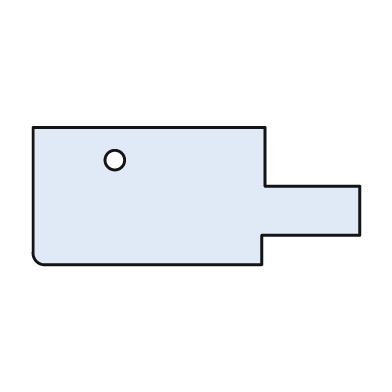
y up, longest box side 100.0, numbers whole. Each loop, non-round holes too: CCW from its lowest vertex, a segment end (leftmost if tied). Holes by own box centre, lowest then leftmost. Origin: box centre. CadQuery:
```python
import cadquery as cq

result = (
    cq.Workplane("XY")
    .moveTo(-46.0, -21.0)
    .lineTo(20.0, -21.0)
    .lineTo(20.0, -12.0)
    .lineTo(50.0, -12.0)
    .lineTo(50.0, 3.0)
    .lineTo(21.0, 3.0)
    .lineTo(21.0, 21.0)
    .lineTo(-50.0, 21.0)
    .lineTo(-50.0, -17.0)
    .threePointArc((-49.0, -20.0), (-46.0, -21.0))
    .close()
    .moveTo(-25.0, 11.0)
    .circle(3.0)
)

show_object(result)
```